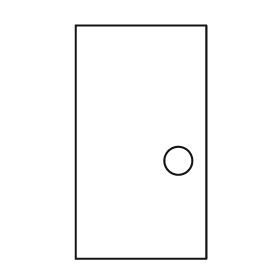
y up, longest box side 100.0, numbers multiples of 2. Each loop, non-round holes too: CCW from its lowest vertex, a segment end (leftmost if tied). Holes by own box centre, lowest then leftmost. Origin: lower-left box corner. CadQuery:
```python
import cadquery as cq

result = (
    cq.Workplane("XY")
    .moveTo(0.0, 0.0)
    .lineTo(56.0, 0.0)
    .lineTo(56.0, 100.0)
    .lineTo(0.0, 100.0)
    .close()
    .moveTo(44.0, 42.0)
    .circle(6.0)
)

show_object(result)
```